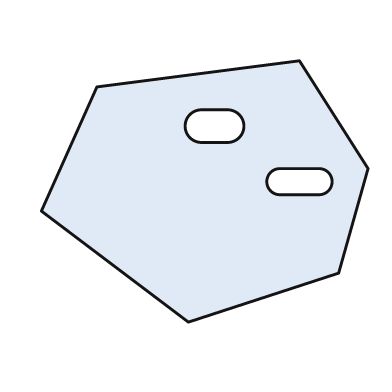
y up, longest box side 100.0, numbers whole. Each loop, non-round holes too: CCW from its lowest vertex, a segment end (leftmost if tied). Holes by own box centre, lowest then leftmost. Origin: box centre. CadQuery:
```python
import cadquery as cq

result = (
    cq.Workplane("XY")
    .moveTo(-5.0, -40.0)
    .lineTo(41.0, -25.0)
    .lineTo(50.0, 7.0)
    .lineTo(29.0, 40.0)
    .lineTo(-33.0, 32.0)
    .lineTo(-50.0, -6.0)
    .close()
    .moveTo(23.0, -1.0)
    .lineTo(35.0, -1.0)
    .threePointArc((39.0, 3.0), (35.0, 7.0))
    .lineTo(23.0, 7.0)
    .threePointArc((19.0, 3.0), (23.0, -1.0))
    .close()
    .moveTo(-1.0, 15.0)
    .lineTo(7.0, 15.0)
    .threePointArc((12.0, 20.0), (7.0, 25.0))
    .lineTo(-1.0, 25.0)
    .threePointArc((-6.0, 20.0), (-1.0, 15.0))
    .close()
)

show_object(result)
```